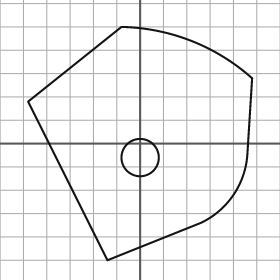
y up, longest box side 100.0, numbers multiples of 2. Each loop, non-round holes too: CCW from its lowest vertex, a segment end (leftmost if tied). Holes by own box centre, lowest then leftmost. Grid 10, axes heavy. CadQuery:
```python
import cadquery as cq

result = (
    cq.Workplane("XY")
    .moveTo(-14.0, -50.0)
    .lineTo(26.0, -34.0)
    .threePointArc((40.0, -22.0), (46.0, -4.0))
    .lineTo(48.0, 28.0)
    .threePointArc((22.0, 44.0), (-8.0, 50.0))
    .lineTo(-48.0, 18.0)
    .close()
    .moveTo(0.0, -6.0)
    .circle(8.0)
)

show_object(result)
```